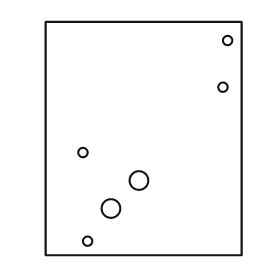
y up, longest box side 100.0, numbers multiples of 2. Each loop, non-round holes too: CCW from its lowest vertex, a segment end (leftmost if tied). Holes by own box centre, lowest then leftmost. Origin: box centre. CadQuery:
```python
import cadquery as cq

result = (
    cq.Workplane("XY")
    .moveTo(-42.0, -50.0)
    .lineTo(42.0, -50.0)
    .lineTo(42.0, 50.0)
    .lineTo(-42.0, 50.0)
    .close()
    .moveTo(-24.0, -44.0)
    .circle(2.0)
    .moveTo(-14.0, -30.0)
    .circle(4.0)
    .moveTo(-2.0, -18.0)
    .circle(4.0)
    .moveTo(-26.0, -6.0)
    .circle(2.0)
    .moveTo(34.0, 22.0)
    .circle(2.0)
    .moveTo(36.0, 42.0)
    .circle(2.0)
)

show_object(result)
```